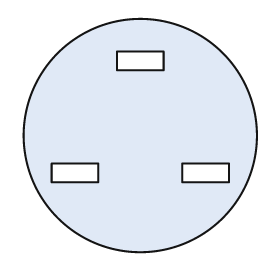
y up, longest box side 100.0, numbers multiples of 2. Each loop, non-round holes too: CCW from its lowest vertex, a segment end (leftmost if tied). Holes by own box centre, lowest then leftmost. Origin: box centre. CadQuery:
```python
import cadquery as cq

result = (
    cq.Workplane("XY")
    .moveTo(0.0, 0.0)
    .circle(50.0)
    .moveTo(-38.0, -20.0)
    .lineTo(-18.0, -20.0)
    .lineTo(-18.0, -12.0)
    .lineTo(-38.0, -12.0)
    .close()
    .moveTo(18.0, -20.0)
    .lineTo(38.0, -20.0)
    .lineTo(38.0, -12.0)
    .lineTo(18.0, -12.0)
    .close()
    .moveTo(-10.0, 28.0)
    .lineTo(10.0, 28.0)
    .lineTo(10.0, 36.0)
    .lineTo(-10.0, 36.0)
    .close()
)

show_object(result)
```